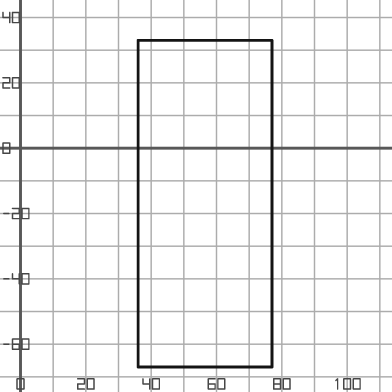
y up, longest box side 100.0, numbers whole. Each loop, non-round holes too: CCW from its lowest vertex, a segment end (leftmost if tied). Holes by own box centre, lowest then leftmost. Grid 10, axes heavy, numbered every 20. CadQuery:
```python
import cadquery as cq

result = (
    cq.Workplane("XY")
    .moveTo(36.0, -67.0)
    .lineTo(77.0, -67.0)
    .lineTo(77.0, 33.0)
    .lineTo(36.0, 33.0)
    .close()
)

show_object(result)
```